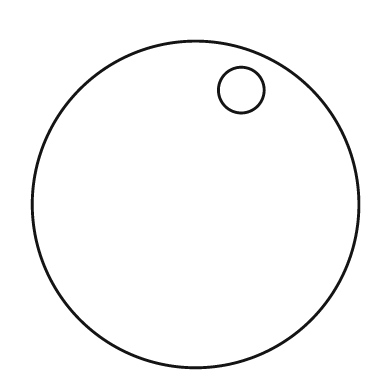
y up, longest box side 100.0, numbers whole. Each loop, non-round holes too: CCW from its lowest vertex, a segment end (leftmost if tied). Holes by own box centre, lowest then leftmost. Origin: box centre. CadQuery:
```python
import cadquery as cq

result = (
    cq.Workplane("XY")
    .moveTo(0.0, 0.0)
    .circle(50.0)
    .moveTo(14.0, 35.0)
    .circle(7.0)
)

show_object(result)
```